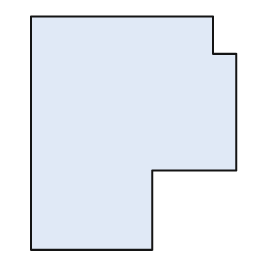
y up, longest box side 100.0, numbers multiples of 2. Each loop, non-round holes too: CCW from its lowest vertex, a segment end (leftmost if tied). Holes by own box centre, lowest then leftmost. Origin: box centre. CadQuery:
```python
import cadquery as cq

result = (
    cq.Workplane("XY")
    .moveTo(-44.0, -50.0)
    .lineTo(8.0, -50.0)
    .lineTo(8.0, -16.0)
    .lineTo(44.0, -16.0)
    .lineTo(44.0, 34.0)
    .lineTo(34.0, 34.0)
    .lineTo(34.0, 50.0)
    .lineTo(-44.0, 50.0)
    .close()
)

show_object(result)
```